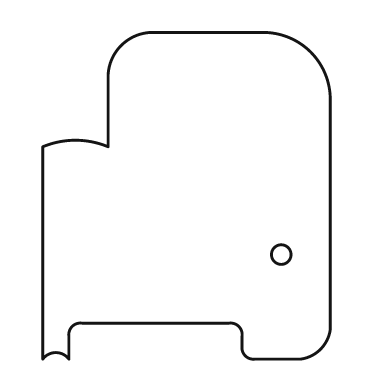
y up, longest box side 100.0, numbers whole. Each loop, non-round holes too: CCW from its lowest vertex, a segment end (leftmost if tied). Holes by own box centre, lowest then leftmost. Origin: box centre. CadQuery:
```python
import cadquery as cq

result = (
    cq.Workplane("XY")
    .moveTo(-44.0, -50.0)
    .threePointArc((-40.0, -48.0), (-36.0, -50.0))
    .lineTo(-36.0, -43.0)
    .threePointArc((-35.0, -40.0), (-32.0, -39.0))
    .lineTo(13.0, -39.0)
    .threePointArc((16.0, -40.0), (17.0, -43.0))
    .lineTo(17.0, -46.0)
    .threePointArc((18.0, -49.0), (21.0, -50.0))
    .lineTo(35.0, -50.0)
    .threePointArc((41.0, -47.0), (44.0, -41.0))
    .lineTo(44.0, 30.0)
    .threePointArc((38.0, 44.0), (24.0, 50.0))
    .lineTo(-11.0, 50.0)
    .threePointArc((-20.0, 46.0), (-24.0, 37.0))
    .lineTo(-24.0, 15.0)
    .threePointArc((-34.0, 17.0), (-44.0, 15.0))
    .close()
    .moveTo(29.0, -18.0)
    .circle(3.0)
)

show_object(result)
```